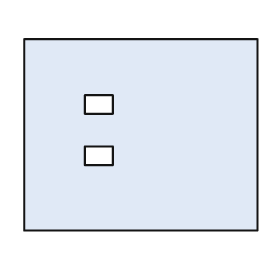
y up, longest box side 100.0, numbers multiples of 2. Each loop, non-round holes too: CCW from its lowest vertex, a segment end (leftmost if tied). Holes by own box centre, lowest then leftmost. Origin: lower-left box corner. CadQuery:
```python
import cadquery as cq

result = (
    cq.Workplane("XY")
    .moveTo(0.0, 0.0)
    .lineTo(100.0, 0.0)
    .lineTo(100.0, 82.0)
    .lineTo(0.0, 82.0)
    .close()
    .moveTo(26.0, 28.0)
    .lineTo(38.0, 28.0)
    .lineTo(38.0, 36.0)
    .lineTo(26.0, 36.0)
    .close()
    .moveTo(26.0, 50.0)
    .lineTo(38.0, 50.0)
    .lineTo(38.0, 58.0)
    .lineTo(26.0, 58.0)
    .close()
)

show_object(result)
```